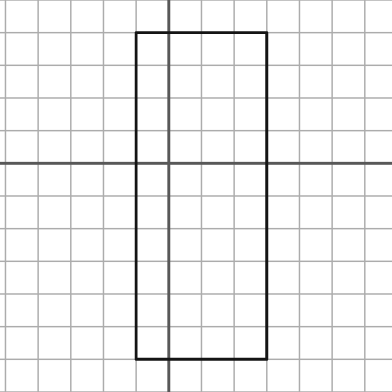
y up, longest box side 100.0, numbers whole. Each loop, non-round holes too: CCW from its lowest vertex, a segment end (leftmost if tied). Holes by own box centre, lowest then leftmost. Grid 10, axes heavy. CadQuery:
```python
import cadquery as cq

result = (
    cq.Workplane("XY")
    .moveTo(-10.0, -60.0)
    .lineTo(30.0, -60.0)
    .lineTo(30.0, 40.0)
    .lineTo(-10.0, 40.0)
    .close()
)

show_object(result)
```